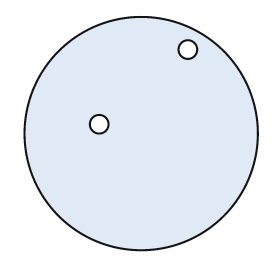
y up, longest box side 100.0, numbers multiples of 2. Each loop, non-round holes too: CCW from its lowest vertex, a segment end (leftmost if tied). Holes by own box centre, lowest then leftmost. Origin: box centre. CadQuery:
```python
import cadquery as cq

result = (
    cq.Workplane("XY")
    .moveTo(0.0, 0.0)
    .circle(50.0)
    .moveTo(-18.0, 4.0)
    .circle(4.0)
    .moveTo(20.0, 36.0)
    .circle(4.0)
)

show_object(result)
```